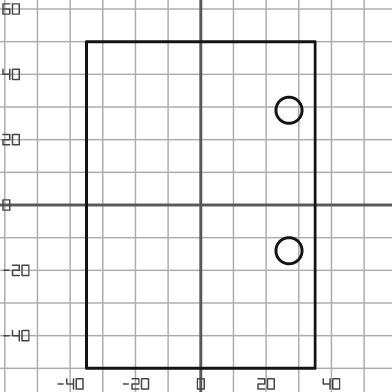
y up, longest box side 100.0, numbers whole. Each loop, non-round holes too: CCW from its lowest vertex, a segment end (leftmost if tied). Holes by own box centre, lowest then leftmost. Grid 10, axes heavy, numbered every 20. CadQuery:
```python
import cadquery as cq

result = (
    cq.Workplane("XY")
    .moveTo(-35.0, -50.0)
    .lineTo(35.0, -50.0)
    .lineTo(35.0, 50.0)
    .lineTo(-35.0, 50.0)
    .close()
    .moveTo(27.0, -14.0)
    .circle(4.0)
    .moveTo(27.0, 29.0)
    .circle(4.0)
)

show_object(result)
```